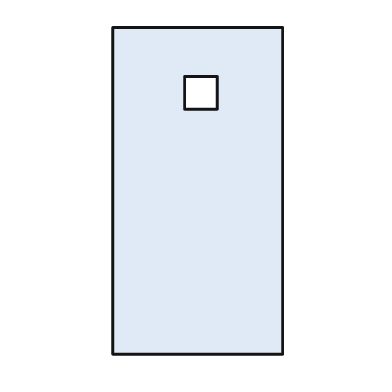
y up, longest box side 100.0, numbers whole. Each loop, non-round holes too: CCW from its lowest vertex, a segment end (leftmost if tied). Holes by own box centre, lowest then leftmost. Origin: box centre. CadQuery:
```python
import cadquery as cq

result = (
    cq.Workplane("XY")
    .moveTo(-26.0, -50.0)
    .lineTo(26.0, -50.0)
    .lineTo(26.0, 50.0)
    .lineTo(-26.0, 50.0)
    .close()
    .moveTo(-4.0, 25.0)
    .lineTo(6.0, 25.0)
    .lineTo(6.0, 35.0)
    .lineTo(-4.0, 35.0)
    .close()
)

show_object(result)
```